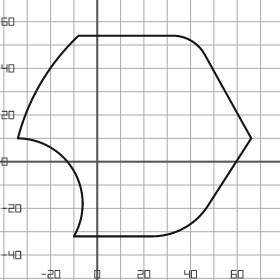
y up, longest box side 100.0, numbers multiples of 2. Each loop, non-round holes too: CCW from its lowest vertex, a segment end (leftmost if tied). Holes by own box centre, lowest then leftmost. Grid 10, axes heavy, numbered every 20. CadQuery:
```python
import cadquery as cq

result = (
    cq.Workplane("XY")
    .moveTo(-10.0, -32.0)
    .lineTo(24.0, -32.0)
    .threePointArc((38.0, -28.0), (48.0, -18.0))
    .lineTo(66.0, 10.0)
    .lineTo(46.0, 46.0)
    .threePointArc((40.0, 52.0), (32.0, 54.0))
    .lineTo(-8.0, 54.0)
    .threePointArc((-24.0, 34.0), (-34.0, 10.0))
    .threePointArc((-10.0, -4.0), (-10.0, -32.0))
    .close()
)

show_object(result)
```